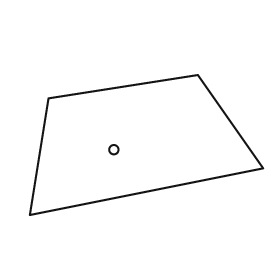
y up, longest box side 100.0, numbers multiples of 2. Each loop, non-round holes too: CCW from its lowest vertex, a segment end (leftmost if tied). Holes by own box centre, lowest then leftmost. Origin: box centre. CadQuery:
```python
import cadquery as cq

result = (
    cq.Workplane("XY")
    .moveTo(-50.0, -30.0)
    .lineTo(50.0, -10.0)
    .lineTo(22.0, 30.0)
    .lineTo(-42.0, 20.0)
    .close()
    .moveTo(-14.0, -2.0)
    .circle(2.0)
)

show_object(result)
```